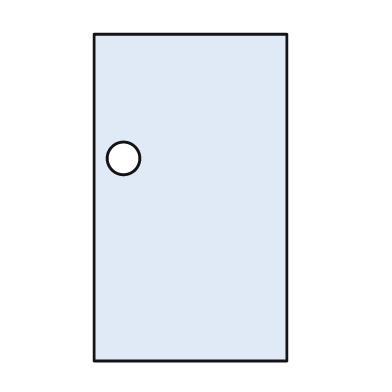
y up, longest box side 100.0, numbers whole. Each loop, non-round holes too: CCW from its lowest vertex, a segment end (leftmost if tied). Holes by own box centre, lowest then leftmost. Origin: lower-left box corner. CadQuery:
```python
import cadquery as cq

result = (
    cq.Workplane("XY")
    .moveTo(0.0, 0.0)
    .lineTo(59.0, 0.0)
    .lineTo(59.0, 100.0)
    .lineTo(0.0, 100.0)
    .close()
    .moveTo(9.0, 62.0)
    .circle(5.0)
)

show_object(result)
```